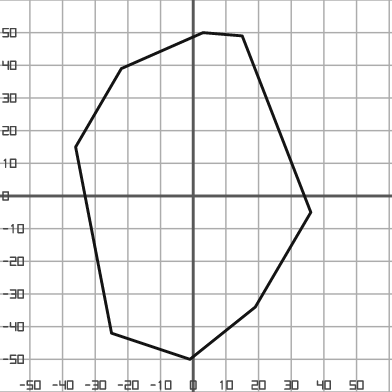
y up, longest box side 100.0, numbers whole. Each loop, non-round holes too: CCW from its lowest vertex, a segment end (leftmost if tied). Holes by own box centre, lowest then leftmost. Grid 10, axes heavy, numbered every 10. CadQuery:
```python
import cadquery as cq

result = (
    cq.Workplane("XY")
    .moveTo(-1.0, -50.0)
    .lineTo(19.0, -34.0)
    .lineTo(36.0, -5.0)
    .lineTo(15.0, 49.0)
    .lineTo(3.0, 50.0)
    .lineTo(-22.0, 39.0)
    .lineTo(-36.0, 15.0)
    .lineTo(-25.0, -42.0)
    .close()
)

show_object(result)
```